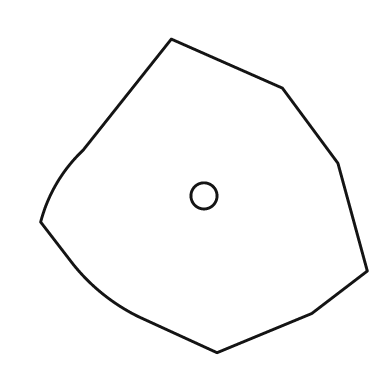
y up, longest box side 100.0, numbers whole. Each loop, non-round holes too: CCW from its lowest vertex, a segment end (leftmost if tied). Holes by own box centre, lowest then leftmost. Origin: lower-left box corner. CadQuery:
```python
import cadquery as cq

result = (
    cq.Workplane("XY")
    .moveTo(54.0, 0.0)
    .lineTo(83.0, 12.0)
    .lineTo(100.0, 25.0)
    .lineTo(91.0, 58.0)
    .lineTo(74.0, 81.0)
    .lineTo(40.0, 96.0)
    .lineTo(13.0, 62.0)
    .threePointArc((5.0, 52.0), (0.0, 40.0))
    .lineTo(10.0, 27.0)
    .threePointArc((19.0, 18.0), (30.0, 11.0))
    .close()
    .moveTo(50.0, 48.0)
    .circle(4.0)
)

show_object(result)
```